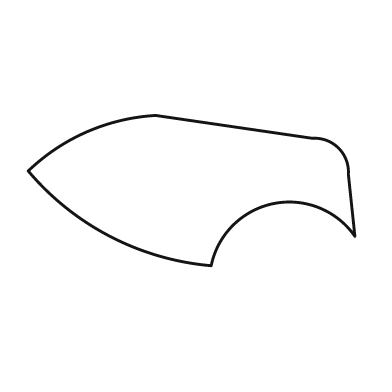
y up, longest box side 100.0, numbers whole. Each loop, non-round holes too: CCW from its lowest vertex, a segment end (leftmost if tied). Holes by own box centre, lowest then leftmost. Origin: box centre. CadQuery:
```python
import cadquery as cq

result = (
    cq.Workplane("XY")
    .moveTo(6.0, -23.0)
    .threePointArc((25.0, -4.0), (50.0, -14.0))
    .lineTo(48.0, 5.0)
    .threePointArc((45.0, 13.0), (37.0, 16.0))
    .lineTo(-11.0, 23.0)
    .threePointArc((-32.0, 18.0), (-50.0, 6.0))
    .threePointArc((-25.0, -14.0), (6.0, -23.0))
    .close()
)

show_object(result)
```